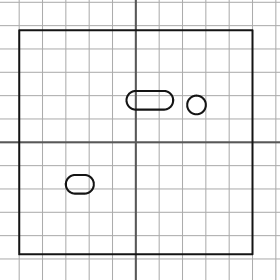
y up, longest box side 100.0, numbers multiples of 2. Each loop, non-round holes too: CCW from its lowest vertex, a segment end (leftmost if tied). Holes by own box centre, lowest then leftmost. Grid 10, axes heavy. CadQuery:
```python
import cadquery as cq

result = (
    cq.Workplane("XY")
    .moveTo(-50.0, -48.0)
    .lineTo(50.0, -48.0)
    .lineTo(50.0, 48.0)
    .lineTo(-50.0, 48.0)
    .close()
    .moveTo(-26.0, -22.0)
    .lineTo(-22.0, -22.0)
    .threePointArc((-18.0, -18.0), (-22.0, -14.0))
    .lineTo(-26.0, -14.0)
    .threePointArc((-30.0, -18.0), (-26.0, -22.0))
    .close()
    .moveTo(26.0, 16.0)
    .circle(4.0)
    .moveTo(0.0, 14.0)
    .lineTo(12.0, 14.0)
    .threePointArc((16.0, 18.0), (12.0, 22.0))
    .lineTo(0.0, 22.0)
    .threePointArc((-4.0, 18.0), (0.0, 14.0))
    .close()
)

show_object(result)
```